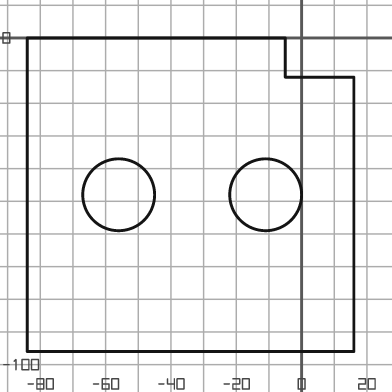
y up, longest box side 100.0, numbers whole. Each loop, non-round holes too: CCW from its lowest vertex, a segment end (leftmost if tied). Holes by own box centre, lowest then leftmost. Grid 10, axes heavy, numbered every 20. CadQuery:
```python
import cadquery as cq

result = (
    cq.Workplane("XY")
    .moveTo(-84.0, -96.0)
    .lineTo(16.0, -96.0)
    .lineTo(16.0, -12.0)
    .lineTo(-5.0, -12.0)
    .lineTo(-5.0, 0.0)
    .lineTo(-84.0, 0.0)
    .close()
    .moveTo(-56.0, -48.0)
    .circle(11.0)
    .moveTo(-11.0, -48.0)
    .circle(11.0)
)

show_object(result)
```